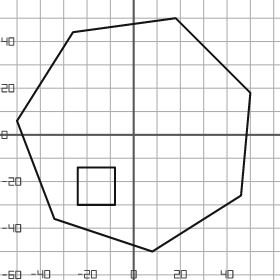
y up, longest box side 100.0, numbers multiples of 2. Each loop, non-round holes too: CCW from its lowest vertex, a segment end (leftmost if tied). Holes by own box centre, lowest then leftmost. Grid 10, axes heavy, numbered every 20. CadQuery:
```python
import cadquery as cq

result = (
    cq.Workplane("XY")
    .moveTo(8.0, -50.0)
    .lineTo(46.0, -26.0)
    .lineTo(50.0, 18.0)
    .lineTo(18.0, 50.0)
    .lineTo(-26.0, 44.0)
    .lineTo(-50.0, 6.0)
    .lineTo(-34.0, -36.0)
    .close()
    .moveTo(-24.0, -30.0)
    .lineTo(-8.0, -30.0)
    .lineTo(-8.0, -14.0)
    .lineTo(-24.0, -14.0)
    .close()
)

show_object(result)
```